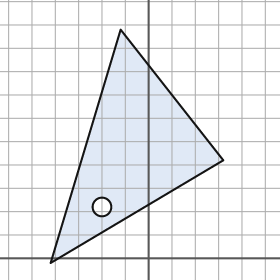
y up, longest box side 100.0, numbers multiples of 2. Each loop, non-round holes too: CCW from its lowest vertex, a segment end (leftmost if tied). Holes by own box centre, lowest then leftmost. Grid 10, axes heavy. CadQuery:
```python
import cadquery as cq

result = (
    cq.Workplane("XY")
    .moveTo(-42.0, -2.0)
    .lineTo(32.0, 42.0)
    .lineTo(-12.0, 98.0)
    .close()
    .moveTo(-20.0, 22.0)
    .circle(4.0)
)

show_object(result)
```